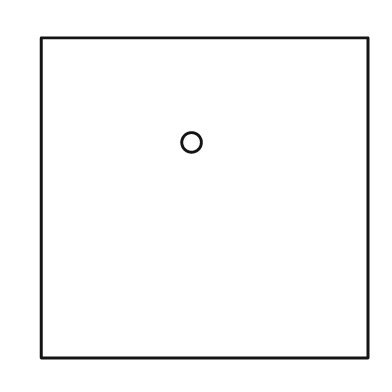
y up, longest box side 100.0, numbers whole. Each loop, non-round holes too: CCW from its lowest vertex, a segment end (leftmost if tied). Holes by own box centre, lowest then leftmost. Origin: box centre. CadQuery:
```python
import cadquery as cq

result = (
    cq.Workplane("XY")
    .moveTo(-50.0, -49.0)
    .lineTo(50.0, -49.0)
    .lineTo(50.0, 49.0)
    .lineTo(-50.0, 49.0)
    .close()
    .moveTo(-4.0, 17.0)
    .circle(3.0)
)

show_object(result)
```